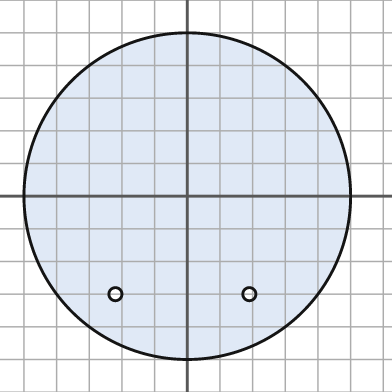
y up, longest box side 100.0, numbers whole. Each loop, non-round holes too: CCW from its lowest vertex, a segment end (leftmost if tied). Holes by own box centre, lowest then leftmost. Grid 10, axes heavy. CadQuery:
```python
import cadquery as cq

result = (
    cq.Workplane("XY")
    .moveTo(0.0, 0.0)
    .circle(50.0)
    .moveTo(-22.0, -30.0)
    .circle(2.0)
    .moveTo(19.0, -30.0)
    .circle(2.0)
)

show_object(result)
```